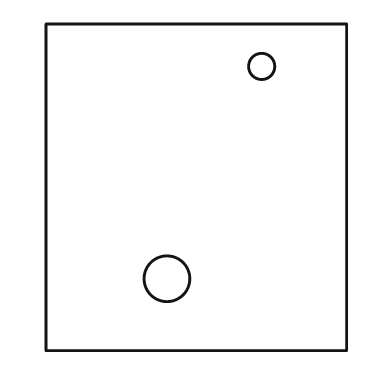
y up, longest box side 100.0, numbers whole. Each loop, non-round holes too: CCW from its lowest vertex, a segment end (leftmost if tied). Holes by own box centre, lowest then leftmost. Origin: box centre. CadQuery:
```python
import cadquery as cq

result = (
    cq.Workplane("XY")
    .moveTo(-46.0, -50.0)
    .lineTo(46.0, -50.0)
    .lineTo(46.0, 50.0)
    .lineTo(-46.0, 50.0)
    .close()
    .moveTo(-9.0, -28.0)
    .circle(7.0)
    .moveTo(20.0, 37.0)
    .circle(4.0)
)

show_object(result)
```